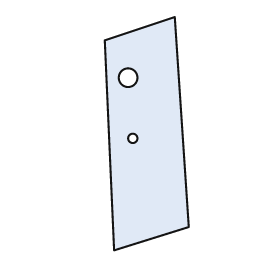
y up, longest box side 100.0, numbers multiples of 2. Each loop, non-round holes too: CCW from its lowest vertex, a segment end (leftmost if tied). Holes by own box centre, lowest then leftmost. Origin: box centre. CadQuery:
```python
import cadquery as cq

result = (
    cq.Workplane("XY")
    .moveTo(-14.0, -50.0)
    .lineTo(18.0, -40.0)
    .lineTo(12.0, 50.0)
    .lineTo(-18.0, 40.0)
    .close()
    .moveTo(-6.0, -2.0)
    .circle(2.0)
    .moveTo(-8.0, 24.0)
    .circle(4.0)
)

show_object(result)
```